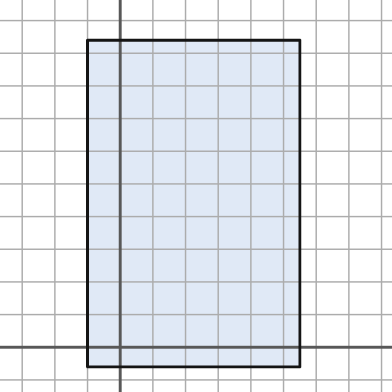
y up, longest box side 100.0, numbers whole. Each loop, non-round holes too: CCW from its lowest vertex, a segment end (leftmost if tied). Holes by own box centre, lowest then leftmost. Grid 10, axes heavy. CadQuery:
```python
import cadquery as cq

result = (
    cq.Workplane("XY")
    .moveTo(-10.0, -6.0)
    .lineTo(55.0, -6.0)
    .lineTo(55.0, 94.0)
    .lineTo(-10.0, 94.0)
    .close()
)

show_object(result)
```